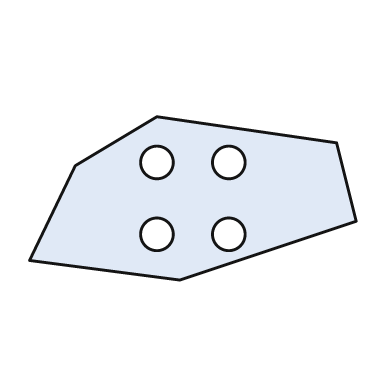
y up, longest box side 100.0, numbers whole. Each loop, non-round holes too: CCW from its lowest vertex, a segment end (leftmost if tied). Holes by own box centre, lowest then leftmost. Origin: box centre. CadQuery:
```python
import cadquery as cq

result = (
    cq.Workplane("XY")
    .moveTo(-4.0, -25.0)
    .lineTo(50.0, -7.0)
    .lineTo(44.0, 17.0)
    .lineTo(-11.0, 25.0)
    .lineTo(-36.0, 10.0)
    .lineTo(-50.0, -19.0)
    .close()
    .moveTo(-11.0, -11.0)
    .circle(5.0)
    .moveTo(11.0, -11.0)
    .circle(5.0)
    .moveTo(-11.0, 11.0)
    .circle(5.0)
    .moveTo(11.0, 11.0)
    .circle(5.0)
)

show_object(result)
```